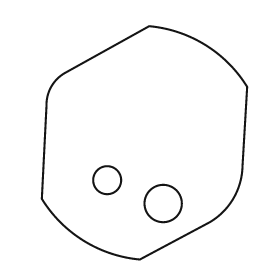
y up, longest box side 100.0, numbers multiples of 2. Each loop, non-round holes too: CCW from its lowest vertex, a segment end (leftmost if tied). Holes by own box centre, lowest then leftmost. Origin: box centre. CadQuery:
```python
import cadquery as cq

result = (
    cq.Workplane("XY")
    .moveTo(-2.0, -50.0)
    .lineTo(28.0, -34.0)
    .threePointArc((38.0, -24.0), (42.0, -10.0))
    .lineTo(44.0, 24.0)
    .threePointArc((26.0, 42.0), (2.0, 50.0))
    .lineTo(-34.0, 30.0)
    .threePointArc((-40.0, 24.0), (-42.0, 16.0))
    .lineTo(-44.0, -24.0)
    .threePointArc((-26.0, -42.0), (-2.0, -50.0))
    .close()
    .moveTo(8.0, -26.0)
    .circle(8.0)
    .moveTo(-16.0, -16.0)
    .circle(6.0)
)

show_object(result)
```